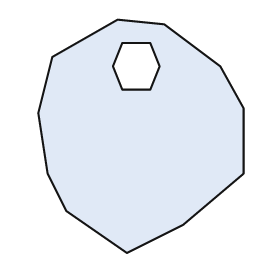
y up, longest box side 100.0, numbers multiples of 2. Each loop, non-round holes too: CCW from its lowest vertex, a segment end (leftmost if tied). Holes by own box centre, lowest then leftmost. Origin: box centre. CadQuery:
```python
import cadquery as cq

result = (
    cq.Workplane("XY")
    .moveTo(-6.0, -50.0)
    .lineTo(18.0, -38.0)
    .lineTo(44.0, -16.0)
    .lineTo(44.0, 12.0)
    .lineTo(34.0, 30.0)
    .lineTo(10.0, 48.0)
    .lineTo(-10.0, 50.0)
    .lineTo(-38.0, 34.0)
    .lineTo(-44.0, 10.0)
    .lineTo(-40.0, -16.0)
    .lineTo(-32.0, -32.0)
    .close()
    .moveTo(-8.0, 20.0)
    .lineTo(4.0, 20.0)
    .lineTo(8.0, 30.0)
    .lineTo(4.0, 40.0)
    .lineTo(-8.0, 40.0)
    .lineTo(-12.0, 30.0)
    .close()
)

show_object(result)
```